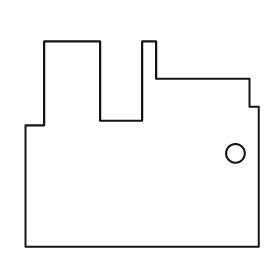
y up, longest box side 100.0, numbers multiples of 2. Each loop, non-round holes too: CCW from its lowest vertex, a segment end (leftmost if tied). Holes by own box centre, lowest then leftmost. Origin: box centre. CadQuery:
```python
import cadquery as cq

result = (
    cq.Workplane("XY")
    .moveTo(-50.0, -44.0)
    .lineTo(50.0, -44.0)
    .lineTo(50.0, 16.0)
    .lineTo(46.0, 16.0)
    .lineTo(46.0, 28.0)
    .lineTo(6.0, 28.0)
    .lineTo(6.0, 44.0)
    .lineTo(0.0, 44.0)
    .lineTo(0.0, 10.0)
    .lineTo(-18.0, 10.0)
    .lineTo(-18.0, 44.0)
    .lineTo(-42.0, 44.0)
    .lineTo(-42.0, 8.0)
    .lineTo(-50.0, 8.0)
    .close()
    .moveTo(40.0, -4.0)
    .circle(4.0)
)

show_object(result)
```